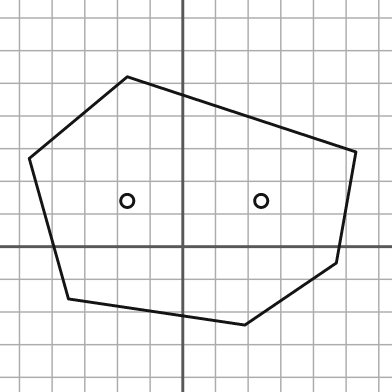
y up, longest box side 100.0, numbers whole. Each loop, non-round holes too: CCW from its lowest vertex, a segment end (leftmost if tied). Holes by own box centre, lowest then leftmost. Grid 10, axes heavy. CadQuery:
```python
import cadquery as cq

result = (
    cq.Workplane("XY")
    .moveTo(19.0, -24.0)
    .lineTo(47.0, -5.0)
    .lineTo(53.0, 29.0)
    .lineTo(-17.0, 52.0)
    .lineTo(-47.0, 27.0)
    .lineTo(-35.0, -16.0)
    .close()
    .moveTo(-17.0, 14.0)
    .circle(2.0)
    .moveTo(24.0, 14.0)
    .circle(2.0)
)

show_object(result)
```